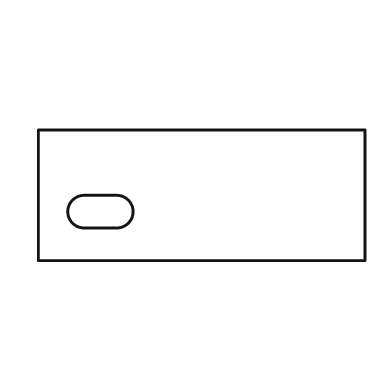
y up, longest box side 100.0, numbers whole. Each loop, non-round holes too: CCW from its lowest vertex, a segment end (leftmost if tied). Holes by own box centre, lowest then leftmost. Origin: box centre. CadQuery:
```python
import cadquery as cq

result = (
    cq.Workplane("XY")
    .moveTo(-50.0, -20.0)
    .lineTo(50.0, -20.0)
    .lineTo(50.0, 20.0)
    .lineTo(-50.0, 20.0)
    .close()
    .moveTo(-36.0, -10.0)
    .lineTo(-26.0, -10.0)
    .threePointArc((-21.0, -5.0), (-26.0, 0.0))
    .lineTo(-36.0, 0.0)
    .threePointArc((-41.0, -5.0), (-36.0, -10.0))
    .close()
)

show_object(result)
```